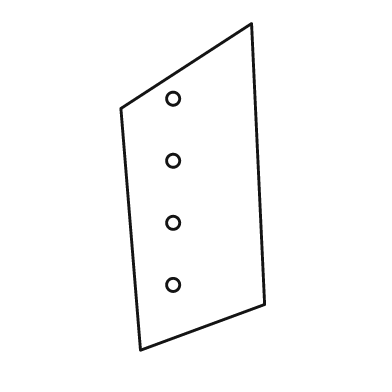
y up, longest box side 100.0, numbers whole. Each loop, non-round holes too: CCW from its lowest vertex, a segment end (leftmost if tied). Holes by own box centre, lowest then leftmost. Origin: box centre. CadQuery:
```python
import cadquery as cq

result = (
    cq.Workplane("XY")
    .moveTo(-16.0, -50.0)
    .lineTo(22.0, -36.0)
    .lineTo(18.0, 50.0)
    .lineTo(-22.0, 24.0)
    .close()
    .moveTo(-6.0, -30.0)
    .circle(2.0)
    .moveTo(-6.0, -11.0)
    .circle(2.0)
    .moveTo(-6.0, 8.0)
    .circle(2.0)
    .moveTo(-6.0, 27.0)
    .circle(2.0)
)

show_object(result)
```